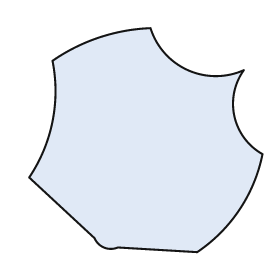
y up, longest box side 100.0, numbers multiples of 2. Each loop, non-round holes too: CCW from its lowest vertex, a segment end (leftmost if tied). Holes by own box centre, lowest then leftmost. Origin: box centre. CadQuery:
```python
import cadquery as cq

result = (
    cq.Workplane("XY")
    .moveTo(22.0, -48.0)
    .threePointArc((40.0, -30.0), (50.0, -6.0))
    .threePointArc((38.0, 10.0), (42.0, 30.0))
    .threePointArc((18.0, 30.0), (2.0, 48.0))
    .threePointArc((-20.0, 44.0), (-40.0, 34.0))
    .threePointArc((-40.0, 8.0), (-50.0, -16.0))
    .lineTo(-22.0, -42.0)
    .threePointArc((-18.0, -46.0), (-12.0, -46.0))
    .close()
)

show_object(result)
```